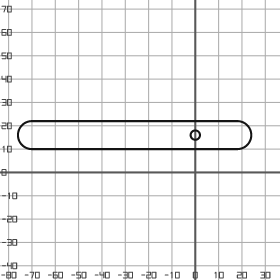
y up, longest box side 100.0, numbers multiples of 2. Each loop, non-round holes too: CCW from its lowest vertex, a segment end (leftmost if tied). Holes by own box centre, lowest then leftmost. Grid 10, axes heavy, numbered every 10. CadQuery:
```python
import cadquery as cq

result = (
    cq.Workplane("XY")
    .moveTo(-70.0, 10.0)
    .lineTo(18.0, 10.0)
    .threePointArc((24.0, 16.0), (18.0, 22.0))
    .lineTo(-70.0, 22.0)
    .threePointArc((-76.0, 16.0), (-70.0, 10.0))
    .close()
    .moveTo(0.0, 16.0)
    .circle(2.0)
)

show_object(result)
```